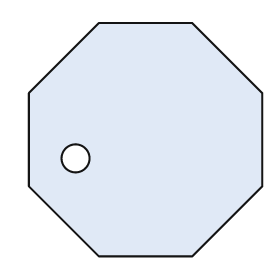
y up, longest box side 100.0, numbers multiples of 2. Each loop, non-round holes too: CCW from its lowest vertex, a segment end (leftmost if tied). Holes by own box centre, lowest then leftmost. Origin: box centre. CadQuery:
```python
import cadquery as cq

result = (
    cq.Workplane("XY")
    .moveTo(-20.0, -50.0)
    .lineTo(20.0, -50.0)
    .lineTo(50.0, -20.0)
    .lineTo(50.0, 20.0)
    .lineTo(20.0, 50.0)
    .lineTo(-20.0, 50.0)
    .lineTo(-50.0, 20.0)
    .lineTo(-50.0, -20.0)
    .close()
    .moveTo(-30.0, -8.0)
    .circle(6.0)
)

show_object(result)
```